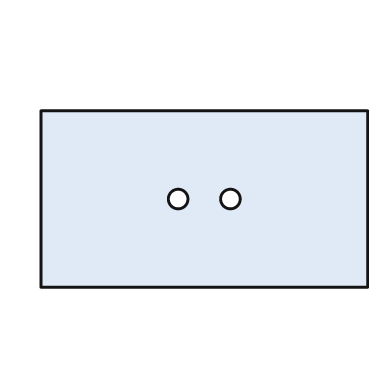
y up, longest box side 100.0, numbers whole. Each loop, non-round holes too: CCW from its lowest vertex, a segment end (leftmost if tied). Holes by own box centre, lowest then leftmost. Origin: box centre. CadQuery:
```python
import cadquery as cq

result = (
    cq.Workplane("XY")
    .moveTo(-50.0, -27.0)
    .lineTo(50.0, -27.0)
    .lineTo(50.0, 27.0)
    .lineTo(-50.0, 27.0)
    .close()
    .moveTo(-8.0, 0.0)
    .circle(3.0)
    .moveTo(8.0, 0.0)
    .circle(3.0)
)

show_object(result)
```